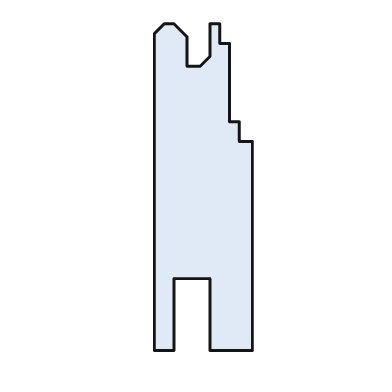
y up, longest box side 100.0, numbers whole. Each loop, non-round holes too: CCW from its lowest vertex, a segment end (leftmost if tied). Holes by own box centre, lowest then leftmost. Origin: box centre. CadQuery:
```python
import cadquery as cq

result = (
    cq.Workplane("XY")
    .moveTo(-15.0, -50.0)
    .lineTo(-9.0, -50.0)
    .lineTo(-9.0, -28.0)
    .lineTo(2.0, -28.0)
    .lineTo(2.0, -50.0)
    .lineTo(15.0, -50.0)
    .lineTo(15.0, 14.0)
    .lineTo(11.0, 14.0)
    .lineTo(11.0, 20.0)
    .lineTo(8.0, 20.0)
    .lineTo(8.0, 44.0)
    .lineTo(5.0, 44.0)
    .lineTo(5.0, 50.0)
    .lineTo(2.0, 50.0)
    .lineTo(2.0, 40.0)
    .lineTo(-1.0, 37.0)
    .lineTo(-5.0, 37.0)
    .lineTo(-5.0, 46.0)
    .lineTo(-9.0, 50.0)
    .lineTo(-12.0, 50.0)
    .lineTo(-15.0, 47.0)
    .close()
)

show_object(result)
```